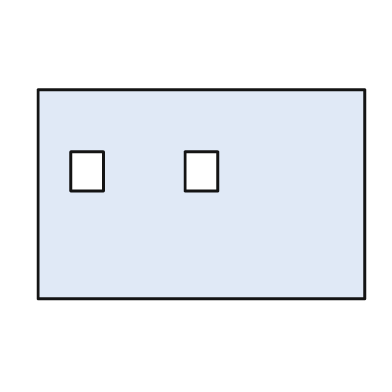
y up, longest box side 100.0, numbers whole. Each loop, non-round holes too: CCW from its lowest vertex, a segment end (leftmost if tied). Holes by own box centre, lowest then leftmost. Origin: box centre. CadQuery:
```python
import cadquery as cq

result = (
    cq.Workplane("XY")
    .moveTo(-50.0, -32.0)
    .lineTo(50.0, -32.0)
    .lineTo(50.0, 32.0)
    .lineTo(-50.0, 32.0)
    .close()
    .moveTo(-40.0, 1.0)
    .lineTo(-30.0, 1.0)
    .lineTo(-30.0, 13.0)
    .lineTo(-40.0, 13.0)
    .close()
    .moveTo(-5.0, 1.0)
    .lineTo(5.0, 1.0)
    .lineTo(5.0, 13.0)
    .lineTo(-5.0, 13.0)
    .close()
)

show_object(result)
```